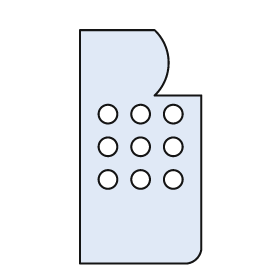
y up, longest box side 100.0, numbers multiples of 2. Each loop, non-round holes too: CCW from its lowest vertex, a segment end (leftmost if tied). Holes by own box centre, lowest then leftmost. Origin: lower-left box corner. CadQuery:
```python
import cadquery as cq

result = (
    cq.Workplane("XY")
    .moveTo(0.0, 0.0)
    .lineTo(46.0, 0.0)
    .threePointArc((50.0, 2.0), (52.0, 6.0))
    .lineTo(52.0, 72.0)
    .lineTo(32.0, 72.0)
    .threePointArc((38.0, 86.0), (32.0, 100.0))
    .lineTo(0.0, 100.0)
    .close()
    .moveTo(12.0, 36.0)
    .circle(4.0)
    .moveTo(26.0, 36.0)
    .circle(4.0)
    .moveTo(40.0, 36.0)
    .circle(4.0)
    .moveTo(12.0, 50.0)
    .circle(4.0)
    .moveTo(26.0, 50.0)
    .circle(4.0)
    .moveTo(40.0, 50.0)
    .circle(4.0)
    .moveTo(12.0, 64.0)
    .circle(4.0)
    .moveTo(26.0, 64.0)
    .circle(4.0)
    .moveTo(40.0, 64.0)
    .circle(4.0)
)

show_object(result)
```